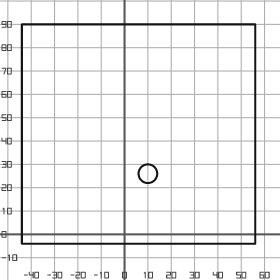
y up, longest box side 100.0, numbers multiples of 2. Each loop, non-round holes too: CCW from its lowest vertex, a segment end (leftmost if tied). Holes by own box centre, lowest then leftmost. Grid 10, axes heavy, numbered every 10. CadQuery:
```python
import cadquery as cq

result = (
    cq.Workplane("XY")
    .moveTo(-44.0, -4.0)
    .lineTo(56.0, -4.0)
    .lineTo(56.0, 90.0)
    .lineTo(-44.0, 90.0)
    .close()
    .moveTo(10.0, 26.0)
    .circle(4.0)
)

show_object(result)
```